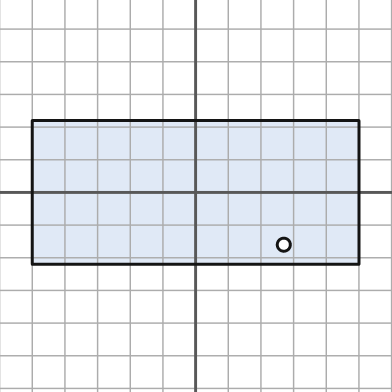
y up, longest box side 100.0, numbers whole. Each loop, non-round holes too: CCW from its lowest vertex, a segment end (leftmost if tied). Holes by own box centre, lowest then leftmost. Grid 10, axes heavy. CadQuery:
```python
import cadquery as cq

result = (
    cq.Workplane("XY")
    .moveTo(-50.0, -22.0)
    .lineTo(50.0, -22.0)
    .lineTo(50.0, 22.0)
    .lineTo(-50.0, 22.0)
    .close()
    .moveTo(27.0, -16.0)
    .circle(2.0)
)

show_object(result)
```